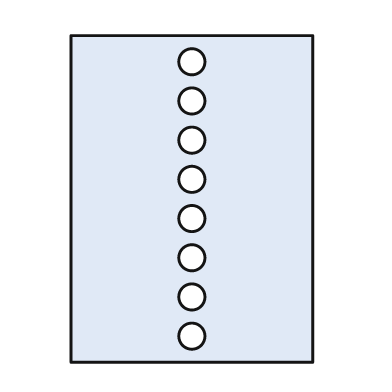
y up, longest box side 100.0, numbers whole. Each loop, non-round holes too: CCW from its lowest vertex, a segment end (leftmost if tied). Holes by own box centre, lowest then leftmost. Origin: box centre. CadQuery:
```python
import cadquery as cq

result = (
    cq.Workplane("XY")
    .moveTo(-37.0, -50.0)
    .lineTo(37.0, -50.0)
    .lineTo(37.0, 50.0)
    .lineTo(-37.0, 50.0)
    .close()
    .moveTo(0.0, -42.0)
    .circle(4.0)
    .moveTo(0.0, -30.0)
    .circle(4.0)
    .moveTo(0.0, -18.0)
    .circle(4.0)
    .moveTo(0.0, -6.0)
    .circle(4.0)
    .moveTo(0.0, 6.0)
    .circle(4.0)
    .moveTo(0.0, 18.0)
    .circle(4.0)
    .moveTo(0.0, 30.0)
    .circle(4.0)
    .moveTo(0.0, 42.0)
    .circle(4.0)
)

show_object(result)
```